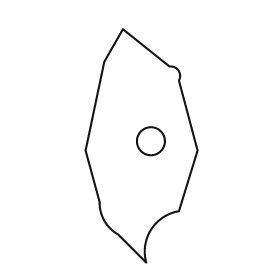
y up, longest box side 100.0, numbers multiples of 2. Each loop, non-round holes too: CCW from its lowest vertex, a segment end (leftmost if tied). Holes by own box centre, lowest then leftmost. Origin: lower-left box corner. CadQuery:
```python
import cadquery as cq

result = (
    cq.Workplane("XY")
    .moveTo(26.0, 0.0)
    .threePointArc((28.0, 14.0), (40.0, 22.0))
    .lineTo(48.0, 48.0)
    .lineTo(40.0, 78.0)
    .threePointArc((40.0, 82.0), (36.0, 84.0))
    .lineTo(16.0, 100.0)
    .lineTo(8.0, 86.0)
    .lineTo(0.0, 48.0)
    .lineTo(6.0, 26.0)
    .threePointArc((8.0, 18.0), (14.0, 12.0))
    .close()
    .moveTo(28.0, 52.0)
    .circle(6.0)
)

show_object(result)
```